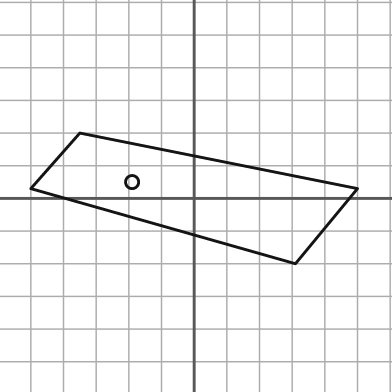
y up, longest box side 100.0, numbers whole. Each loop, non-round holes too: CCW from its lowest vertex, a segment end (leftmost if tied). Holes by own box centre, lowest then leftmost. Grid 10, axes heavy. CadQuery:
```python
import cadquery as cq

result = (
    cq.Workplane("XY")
    .moveTo(31.0, -20.0)
    .lineTo(50.0, 3.0)
    .lineTo(-35.0, 20.0)
    .lineTo(-50.0, 3.0)
    .close()
    .moveTo(-19.0, 5.0)
    .circle(2.0)
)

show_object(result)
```